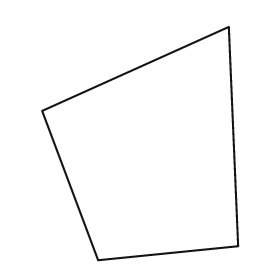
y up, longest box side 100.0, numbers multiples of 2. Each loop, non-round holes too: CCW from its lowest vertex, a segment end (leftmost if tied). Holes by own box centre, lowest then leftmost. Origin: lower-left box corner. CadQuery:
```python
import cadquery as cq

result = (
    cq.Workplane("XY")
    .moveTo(24.0, 0.0)
    .lineTo(84.0, 6.0)
    .lineTo(80.0, 100.0)
    .lineTo(0.0, 64.0)
    .close()
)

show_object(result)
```